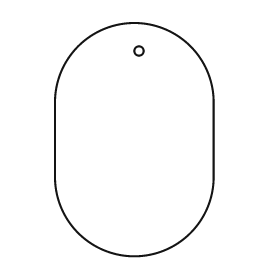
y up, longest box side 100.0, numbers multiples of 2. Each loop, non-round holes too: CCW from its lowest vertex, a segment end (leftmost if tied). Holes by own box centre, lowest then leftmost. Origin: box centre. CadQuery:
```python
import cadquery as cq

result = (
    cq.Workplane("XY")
    .moveTo(-34.0, -16.0)
    .threePointArc((0.0, -50.0), (34.0, -16.0))
    .lineTo(34.0, 16.0)
    .threePointArc((0.0, 50.0), (-34.0, 16.0))
    .close()
    .moveTo(2.0, 38.0)
    .circle(2.0)
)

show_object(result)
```